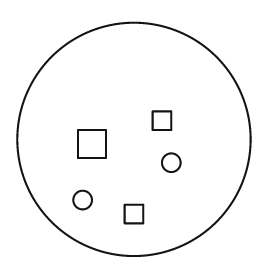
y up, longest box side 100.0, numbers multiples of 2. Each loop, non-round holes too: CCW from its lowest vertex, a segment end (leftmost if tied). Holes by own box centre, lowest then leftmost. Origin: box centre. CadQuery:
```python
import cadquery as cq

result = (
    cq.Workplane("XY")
    .moveTo(0.0, 0.0)
    .circle(50.0)
    .moveTo(-4.0, -36.0)
    .lineTo(4.0, -36.0)
    .lineTo(4.0, -28.0)
    .lineTo(-4.0, -28.0)
    .close()
    .moveTo(-22.0, -26.0)
    .circle(4.0)
    .moveTo(16.0, -10.0)
    .circle(4.0)
    .moveTo(-24.0, -8.0)
    .lineTo(-12.0, -8.0)
    .lineTo(-12.0, 4.0)
    .lineTo(-24.0, 4.0)
    .close()
    .moveTo(8.0, 4.0)
    .lineTo(16.0, 4.0)
    .lineTo(16.0, 12.0)
    .lineTo(8.0, 12.0)
    .close()
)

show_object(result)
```